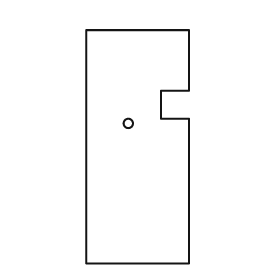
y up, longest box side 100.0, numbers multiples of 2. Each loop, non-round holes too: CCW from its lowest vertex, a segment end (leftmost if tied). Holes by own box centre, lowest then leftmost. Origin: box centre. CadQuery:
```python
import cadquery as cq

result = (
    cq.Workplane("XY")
    .moveTo(-22.0, -50.0)
    .lineTo(22.0, -50.0)
    .lineTo(22.0, 12.0)
    .lineTo(10.0, 12.0)
    .lineTo(10.0, 24.0)
    .lineTo(22.0, 24.0)
    .lineTo(22.0, 50.0)
    .lineTo(-22.0, 50.0)
    .close()
    .moveTo(-4.0, 10.0)
    .circle(2.0)
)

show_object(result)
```